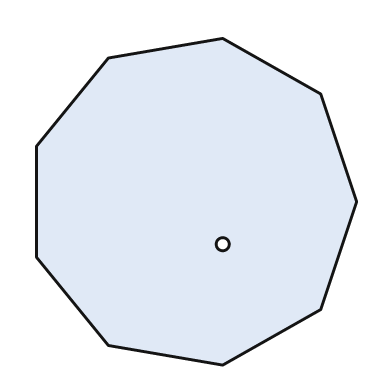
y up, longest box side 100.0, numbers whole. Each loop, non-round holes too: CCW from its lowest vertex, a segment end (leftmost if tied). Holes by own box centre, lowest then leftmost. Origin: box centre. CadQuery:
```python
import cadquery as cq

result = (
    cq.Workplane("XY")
    .moveTo(8.0, -50.0)
    .lineTo(38.0, -33.0)
    .lineTo(49.0, 0.0)
    .lineTo(38.0, 33.0)
    .lineTo(8.0, 50.0)
    .lineTo(-27.0, 44.0)
    .lineTo(-49.0, 17.0)
    .lineTo(-49.0, -17.0)
    .lineTo(-27.0, -44.0)
    .close()
    .moveTo(8.0, -13.0)
    .circle(2.0)
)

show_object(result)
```